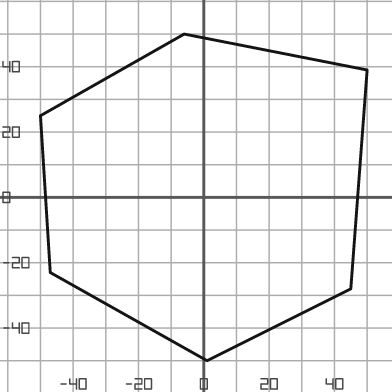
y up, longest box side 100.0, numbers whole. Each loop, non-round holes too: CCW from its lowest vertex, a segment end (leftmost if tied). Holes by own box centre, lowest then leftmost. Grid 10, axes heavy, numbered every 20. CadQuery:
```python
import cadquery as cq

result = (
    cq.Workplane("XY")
    .moveTo(1.0, -50.0)
    .lineTo(45.0, -28.0)
    .lineTo(50.0, 39.0)
    .lineTo(-6.0, 50.0)
    .lineTo(-50.0, 25.0)
    .lineTo(-47.0, -23.0)
    .close()
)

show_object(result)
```